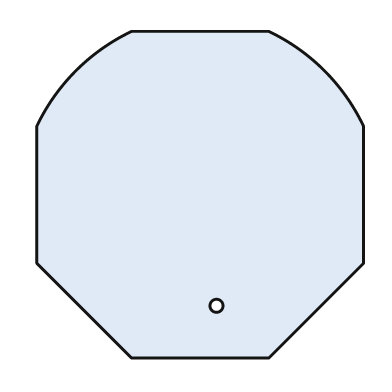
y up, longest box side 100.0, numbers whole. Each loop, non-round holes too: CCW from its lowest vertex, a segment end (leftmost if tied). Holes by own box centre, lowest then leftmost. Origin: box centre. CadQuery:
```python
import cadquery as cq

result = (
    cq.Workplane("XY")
    .moveTo(-21.0, -50.0)
    .lineTo(21.0, -50.0)
    .lineTo(50.0, -21.0)
    .lineTo(50.0, 21.0)
    .threePointArc((38.0, 38.0), (21.0, 50.0))
    .lineTo(-21.0, 50.0)
    .threePointArc((-38.0, 38.0), (-50.0, 21.0))
    .lineTo(-50.0, -21.0)
    .close()
    .moveTo(5.0, -34.0)
    .circle(2.0)
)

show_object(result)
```